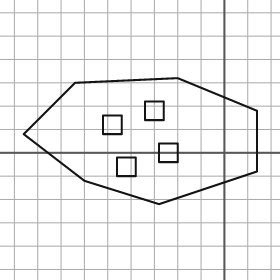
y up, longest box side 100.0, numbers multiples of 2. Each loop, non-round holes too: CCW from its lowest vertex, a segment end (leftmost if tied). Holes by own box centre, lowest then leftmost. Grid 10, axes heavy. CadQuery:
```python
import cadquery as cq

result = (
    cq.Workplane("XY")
    .moveTo(-28.0, -22.0)
    .lineTo(14.0, -8.0)
    .lineTo(14.0, 18.0)
    .lineTo(-20.0, 32.0)
    .lineTo(-64.0, 30.0)
    .lineTo(-86.0, 8.0)
    .lineTo(-60.0, -12.0)
    .close()
    .moveTo(-46.0, -10.0)
    .lineTo(-38.0, -10.0)
    .lineTo(-38.0, -2.0)
    .lineTo(-46.0, -2.0)
    .close()
    .moveTo(-28.0, -4.0)
    .lineTo(-20.0, -4.0)
    .lineTo(-20.0, 4.0)
    .lineTo(-28.0, 4.0)
    .close()
    .moveTo(-52.0, 8.0)
    .lineTo(-44.0, 8.0)
    .lineTo(-44.0, 16.0)
    .lineTo(-52.0, 16.0)
    .close()
    .moveTo(-34.0, 14.0)
    .lineTo(-26.0, 14.0)
    .lineTo(-26.0, 22.0)
    .lineTo(-34.0, 22.0)
    .close()
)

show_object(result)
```